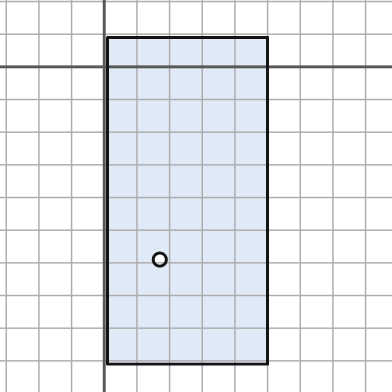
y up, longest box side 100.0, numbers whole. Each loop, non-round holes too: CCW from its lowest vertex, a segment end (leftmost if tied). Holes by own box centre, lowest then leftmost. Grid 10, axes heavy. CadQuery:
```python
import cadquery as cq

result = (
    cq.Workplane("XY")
    .moveTo(1.0, -91.0)
    .lineTo(50.0, -91.0)
    .lineTo(50.0, 9.0)
    .lineTo(1.0, 9.0)
    .close()
    .moveTo(17.0, -59.0)
    .circle(2.0)
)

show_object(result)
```